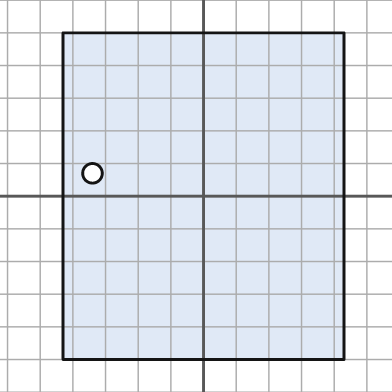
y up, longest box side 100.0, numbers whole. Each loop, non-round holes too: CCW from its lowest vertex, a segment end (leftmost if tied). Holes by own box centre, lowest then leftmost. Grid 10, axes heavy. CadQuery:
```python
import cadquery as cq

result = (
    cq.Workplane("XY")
    .moveTo(-43.0, -50.0)
    .lineTo(43.0, -50.0)
    .lineTo(43.0, 50.0)
    .lineTo(-43.0, 50.0)
    .close()
    .moveTo(-34.0, 7.0)
    .circle(3.0)
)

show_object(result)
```